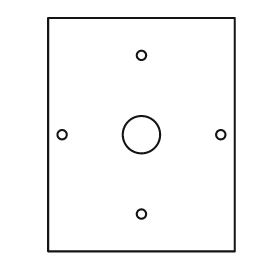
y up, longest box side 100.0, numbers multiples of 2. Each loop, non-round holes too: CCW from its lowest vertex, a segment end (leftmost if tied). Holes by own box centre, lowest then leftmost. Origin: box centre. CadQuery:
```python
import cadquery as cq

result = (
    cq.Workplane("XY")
    .moveTo(-40.0, -50.0)
    .lineTo(40.0, -50.0)
    .lineTo(40.0, 50.0)
    .lineTo(-40.0, 50.0)
    .close()
    .moveTo(0.0, -34.0)
    .circle(2.0)
    .moveTo(-34.0, 0.0)
    .circle(2.0)
    .moveTo(0.0, 0.0)
    .circle(8.0)
    .moveTo(34.0, 0.0)
    .circle(2.0)
    .moveTo(0.0, 34.0)
    .circle(2.0)
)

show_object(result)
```